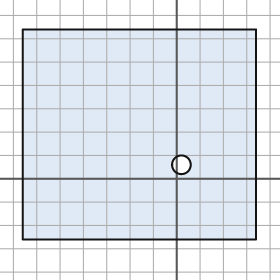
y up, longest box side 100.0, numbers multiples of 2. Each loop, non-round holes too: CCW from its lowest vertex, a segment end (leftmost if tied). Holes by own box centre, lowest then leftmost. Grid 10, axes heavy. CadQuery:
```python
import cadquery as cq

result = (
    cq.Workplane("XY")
    .moveTo(-66.0, -26.0)
    .lineTo(34.0, -26.0)
    .lineTo(34.0, 64.0)
    .lineTo(-66.0, 64.0)
    .close()
    .moveTo(2.0, 6.0)
    .circle(4.0)
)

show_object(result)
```